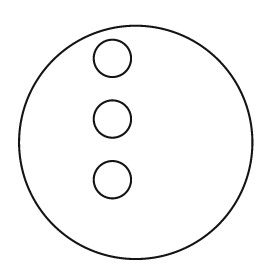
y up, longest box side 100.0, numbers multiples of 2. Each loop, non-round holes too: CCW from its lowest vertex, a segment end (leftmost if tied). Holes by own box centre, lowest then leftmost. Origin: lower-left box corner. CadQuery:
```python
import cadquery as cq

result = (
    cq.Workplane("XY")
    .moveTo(50.0, 50.0)
    .circle(50.0)
    .moveTo(40.0, 34.0)
    .circle(8.0)
    .moveTo(40.0, 60.0)
    .circle(8.0)
    .moveTo(40.0, 86.0)
    .circle(8.0)
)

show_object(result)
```